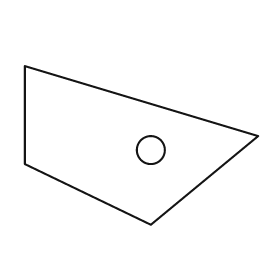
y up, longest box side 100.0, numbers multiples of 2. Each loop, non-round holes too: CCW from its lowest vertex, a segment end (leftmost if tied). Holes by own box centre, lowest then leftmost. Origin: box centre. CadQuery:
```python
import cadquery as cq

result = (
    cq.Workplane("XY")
    .moveTo(4.0, -34.0)
    .lineTo(50.0, 4.0)
    .lineTo(-50.0, 34.0)
    .lineTo(-50.0, -8.0)
    .close()
    .moveTo(4.0, -2.0)
    .circle(6.0)
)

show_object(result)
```